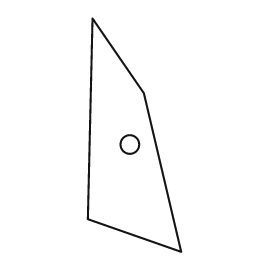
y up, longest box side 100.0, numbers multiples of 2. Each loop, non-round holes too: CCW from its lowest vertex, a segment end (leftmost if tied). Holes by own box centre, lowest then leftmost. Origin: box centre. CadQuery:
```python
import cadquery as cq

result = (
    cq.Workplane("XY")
    .moveTo(20.0, -50.0)
    .lineTo(4.0, 18.0)
    .lineTo(-18.0, 50.0)
    .lineTo(-20.0, -36.0)
    .close()
    .moveTo(-2.0, -4.0)
    .circle(4.0)
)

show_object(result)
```